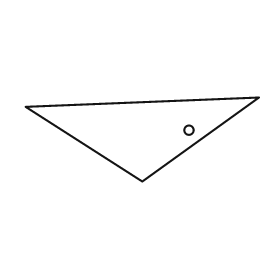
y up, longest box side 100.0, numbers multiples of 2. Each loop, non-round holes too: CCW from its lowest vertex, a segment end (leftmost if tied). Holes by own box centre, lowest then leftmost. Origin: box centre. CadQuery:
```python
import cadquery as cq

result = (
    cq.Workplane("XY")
    .moveTo(0.0, -18.0)
    .lineTo(50.0, 18.0)
    .lineTo(-50.0, 14.0)
    .close()
    .moveTo(20.0, 4.0)
    .circle(2.0)
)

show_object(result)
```